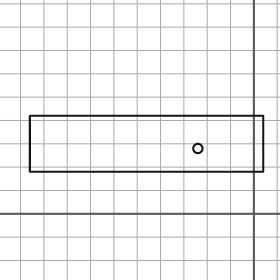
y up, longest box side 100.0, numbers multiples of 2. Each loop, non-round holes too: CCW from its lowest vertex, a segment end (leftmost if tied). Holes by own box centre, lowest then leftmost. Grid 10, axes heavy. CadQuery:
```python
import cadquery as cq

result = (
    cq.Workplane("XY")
    .moveTo(-96.0, 18.0)
    .lineTo(4.0, 18.0)
    .lineTo(4.0, 42.0)
    .lineTo(-96.0, 42.0)
    .close()
    .moveTo(-24.0, 28.0)
    .circle(2.0)
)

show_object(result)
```